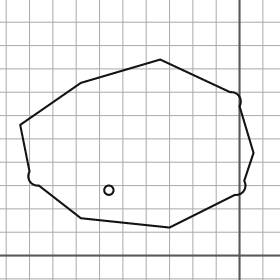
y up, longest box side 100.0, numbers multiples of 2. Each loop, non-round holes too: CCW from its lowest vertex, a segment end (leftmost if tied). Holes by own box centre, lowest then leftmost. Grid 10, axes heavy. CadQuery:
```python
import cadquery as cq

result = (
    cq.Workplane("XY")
    .moveTo(-30.0, 12.0)
    .lineTo(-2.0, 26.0)
    .threePointArc((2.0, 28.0), (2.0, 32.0))
    .lineTo(6.0, 44.0)
    .lineTo(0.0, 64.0)
    .threePointArc((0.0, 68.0), (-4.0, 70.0))
    .lineTo(-34.0, 84.0)
    .lineTo(-68.0, 74.0)
    .lineTo(-94.0, 56.0)
    .lineTo(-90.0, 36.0)
    .threePointArc((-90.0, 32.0), (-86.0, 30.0))
    .lineTo(-68.0, 16.0)
    .close()
    .moveTo(-56.0, 28.0)
    .circle(2.0)
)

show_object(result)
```